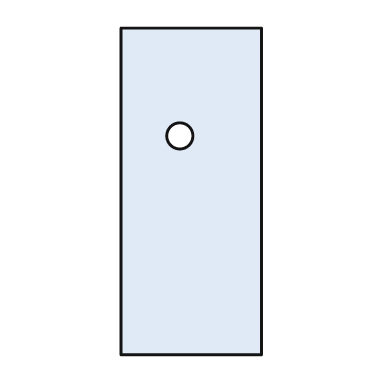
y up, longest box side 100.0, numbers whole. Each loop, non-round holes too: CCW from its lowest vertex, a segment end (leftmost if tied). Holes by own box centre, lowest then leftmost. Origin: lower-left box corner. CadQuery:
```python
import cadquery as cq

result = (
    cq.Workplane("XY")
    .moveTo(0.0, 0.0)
    .lineTo(43.0, 0.0)
    .lineTo(43.0, 100.0)
    .lineTo(0.0, 100.0)
    .close()
    .moveTo(18.0, 67.0)
    .circle(4.0)
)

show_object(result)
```